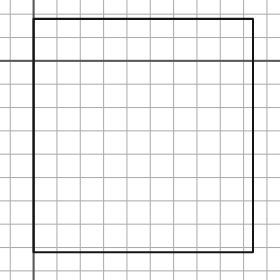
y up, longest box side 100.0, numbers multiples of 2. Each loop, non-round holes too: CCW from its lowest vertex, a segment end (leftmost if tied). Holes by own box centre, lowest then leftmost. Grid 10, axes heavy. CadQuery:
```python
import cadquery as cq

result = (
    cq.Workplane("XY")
    .moveTo(0.0, -82.0)
    .lineTo(94.0, -82.0)
    .lineTo(94.0, 18.0)
    .lineTo(0.0, 18.0)
    .close()
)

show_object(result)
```